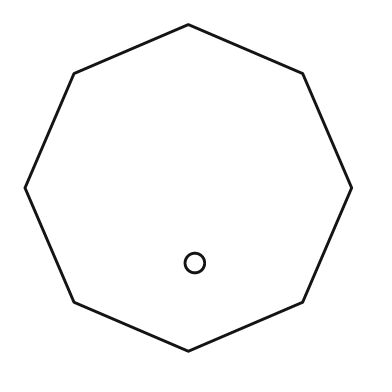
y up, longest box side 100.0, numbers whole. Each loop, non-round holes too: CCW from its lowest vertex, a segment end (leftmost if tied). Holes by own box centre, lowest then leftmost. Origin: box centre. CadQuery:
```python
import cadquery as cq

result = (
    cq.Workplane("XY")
    .moveTo(0.0, -50.0)
    .lineTo(35.0, -35.0)
    .lineTo(50.0, 0.0)
    .lineTo(35.0, 35.0)
    .lineTo(0.0, 50.0)
    .lineTo(-35.0, 35.0)
    .lineTo(-50.0, 0.0)
    .lineTo(-35.0, -35.0)
    .close()
    .moveTo(2.0, -23.0)
    .circle(3.0)
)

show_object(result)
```